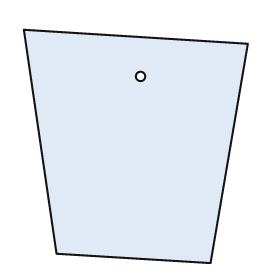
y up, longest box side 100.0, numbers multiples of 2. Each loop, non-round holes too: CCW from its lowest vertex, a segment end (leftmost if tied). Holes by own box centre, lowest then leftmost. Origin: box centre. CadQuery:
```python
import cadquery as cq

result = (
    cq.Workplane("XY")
    .moveTo(32.0, -50.0)
    .lineTo(48.0, 44.0)
    .lineTo(-48.0, 50.0)
    .lineTo(-34.0, -46.0)
    .close()
    .moveTo(2.0, 30.0)
    .circle(2.0)
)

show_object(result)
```